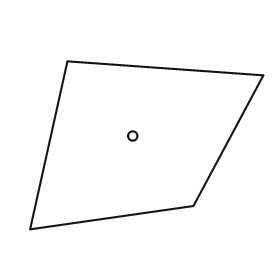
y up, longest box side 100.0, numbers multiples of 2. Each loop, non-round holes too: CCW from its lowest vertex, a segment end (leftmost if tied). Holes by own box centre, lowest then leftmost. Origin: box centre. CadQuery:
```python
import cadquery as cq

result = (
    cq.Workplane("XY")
    .moveTo(-50.0, -36.0)
    .lineTo(20.0, -26.0)
    .lineTo(50.0, 30.0)
    .lineTo(-34.0, 36.0)
    .close()
    .moveTo(-6.0, 4.0)
    .circle(2.0)
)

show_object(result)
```